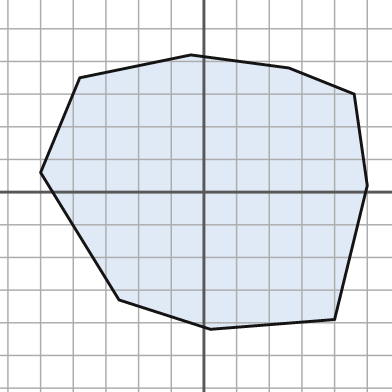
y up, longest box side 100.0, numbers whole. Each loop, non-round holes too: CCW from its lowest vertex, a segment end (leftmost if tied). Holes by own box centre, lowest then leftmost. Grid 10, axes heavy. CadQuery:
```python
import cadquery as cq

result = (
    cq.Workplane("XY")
    .moveTo(2.0, -42.0)
    .lineTo(40.0, -39.0)
    .lineTo(50.0, 2.0)
    .lineTo(46.0, 30.0)
    .lineTo(26.0, 38.0)
    .lineTo(-4.0, 42.0)
    .lineTo(-38.0, 35.0)
    .lineTo(-50.0, 6.0)
    .lineTo(-26.0, -33.0)
    .close()
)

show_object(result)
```